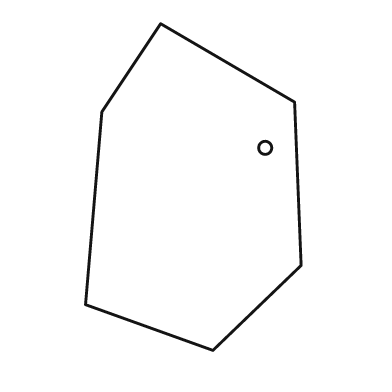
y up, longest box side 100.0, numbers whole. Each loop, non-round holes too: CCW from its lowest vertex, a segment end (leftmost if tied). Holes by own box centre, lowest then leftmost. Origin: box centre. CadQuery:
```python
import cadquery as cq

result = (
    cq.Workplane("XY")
    .moveTo(6.0, -50.0)
    .lineTo(33.0, -24.0)
    .lineTo(31.0, 26.0)
    .lineTo(-10.0, 50.0)
    .lineTo(-28.0, 23.0)
    .lineTo(-33.0, -36.0)
    .close()
    .moveTo(22.0, 12.0)
    .circle(2.0)
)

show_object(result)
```